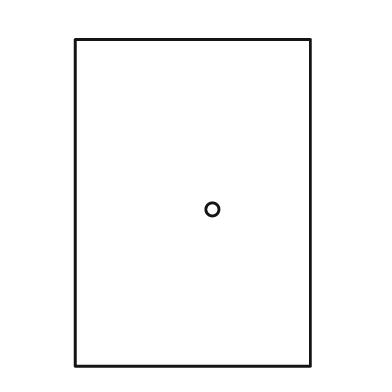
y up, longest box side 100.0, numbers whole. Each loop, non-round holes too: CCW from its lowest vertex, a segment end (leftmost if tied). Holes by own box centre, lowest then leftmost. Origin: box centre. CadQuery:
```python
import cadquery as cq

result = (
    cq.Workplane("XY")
    .moveTo(-36.0, -50.0)
    .lineTo(36.0, -50.0)
    .lineTo(36.0, 50.0)
    .lineTo(-36.0, 50.0)
    .close()
    .moveTo(6.0, -2.0)
    .circle(2.0)
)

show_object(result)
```